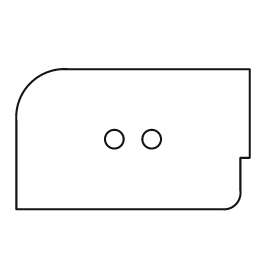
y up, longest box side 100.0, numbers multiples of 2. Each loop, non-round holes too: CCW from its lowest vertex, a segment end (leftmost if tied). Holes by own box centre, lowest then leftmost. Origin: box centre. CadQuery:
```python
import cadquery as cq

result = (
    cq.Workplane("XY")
    .moveTo(-50.0, -30.0)
    .lineTo(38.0, -30.0)
    .threePointArc((44.0, -28.0), (46.0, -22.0))
    .lineTo(46.0, -8.0)
    .lineTo(50.0, -8.0)
    .lineTo(50.0, 30.0)
    .lineTo(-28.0, 30.0)
    .threePointArc((-44.0, 24.0), (-50.0, 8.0))
    .close()
    .moveTo(-8.0, 0.0)
    .circle(4.0)
    .moveTo(8.0, 0.0)
    .circle(4.0)
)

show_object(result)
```